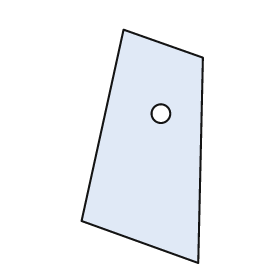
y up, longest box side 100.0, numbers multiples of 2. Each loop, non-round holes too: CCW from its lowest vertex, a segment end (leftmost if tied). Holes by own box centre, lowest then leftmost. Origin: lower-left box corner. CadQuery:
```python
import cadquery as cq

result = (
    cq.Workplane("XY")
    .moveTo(50.0, 0.0)
    .lineTo(52.0, 88.0)
    .lineTo(18.0, 100.0)
    .lineTo(0.0, 18.0)
    .close()
    .moveTo(34.0, 64.0)
    .circle(4.0)
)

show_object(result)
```